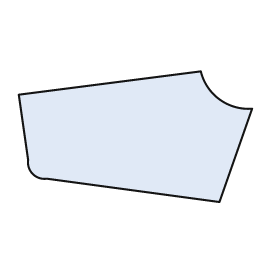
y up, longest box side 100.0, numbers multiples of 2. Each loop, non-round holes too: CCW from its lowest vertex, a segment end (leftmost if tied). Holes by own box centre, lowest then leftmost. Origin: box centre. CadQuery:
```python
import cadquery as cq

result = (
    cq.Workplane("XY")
    .moveTo(36.0, -28.0)
    .lineTo(50.0, 12.0)
    .threePointArc((36.0, 16.0), (28.0, 28.0))
    .lineTo(-50.0, 18.0)
    .lineTo(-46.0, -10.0)
    .threePointArc((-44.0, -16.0), (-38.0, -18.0))
    .close()
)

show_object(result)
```